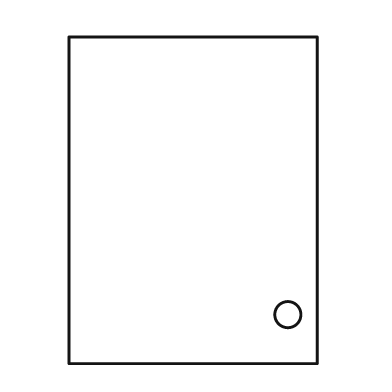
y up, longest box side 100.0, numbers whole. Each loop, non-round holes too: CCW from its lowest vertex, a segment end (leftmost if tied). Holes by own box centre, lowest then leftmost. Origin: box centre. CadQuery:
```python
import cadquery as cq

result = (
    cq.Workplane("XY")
    .moveTo(-38.0, -50.0)
    .lineTo(38.0, -50.0)
    .lineTo(38.0, 50.0)
    .lineTo(-38.0, 50.0)
    .close()
    .moveTo(29.0, -35.0)
    .circle(4.0)
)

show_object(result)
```